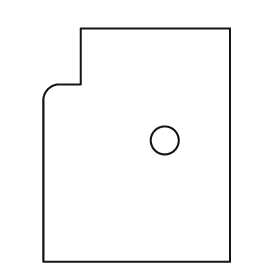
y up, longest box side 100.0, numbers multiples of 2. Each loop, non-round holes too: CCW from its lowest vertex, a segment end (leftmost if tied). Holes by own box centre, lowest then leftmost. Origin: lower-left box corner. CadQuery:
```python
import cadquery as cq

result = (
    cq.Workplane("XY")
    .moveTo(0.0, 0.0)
    .lineTo(80.0, 0.0)
    .lineTo(80.0, 100.0)
    .lineTo(16.0, 100.0)
    .lineTo(16.0, 76.0)
    .lineTo(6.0, 76.0)
    .threePointArc((2.0, 74.0), (0.0, 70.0))
    .close()
    .moveTo(52.0, 52.0)
    .circle(6.0)
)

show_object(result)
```